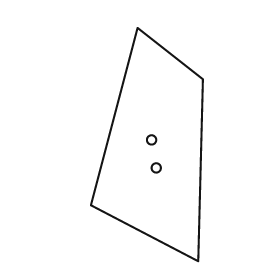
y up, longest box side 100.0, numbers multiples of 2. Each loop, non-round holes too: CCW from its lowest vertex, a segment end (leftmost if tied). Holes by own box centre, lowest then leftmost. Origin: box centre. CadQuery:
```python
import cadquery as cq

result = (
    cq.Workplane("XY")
    .moveTo(22.0, -50.0)
    .lineTo(24.0, 28.0)
    .lineTo(-4.0, 50.0)
    .lineTo(-24.0, -26.0)
    .close()
    .moveTo(4.0, -10.0)
    .circle(2.0)
    .moveTo(2.0, 2.0)
    .circle(2.0)
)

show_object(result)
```